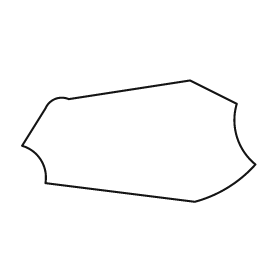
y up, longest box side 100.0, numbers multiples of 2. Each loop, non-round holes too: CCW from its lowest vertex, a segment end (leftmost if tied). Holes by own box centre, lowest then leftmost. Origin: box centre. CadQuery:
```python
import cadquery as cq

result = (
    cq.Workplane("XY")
    .moveTo(24.0, -26.0)
    .threePointArc((38.0, -20.0), (50.0, -10.0))
    .threePointArc((42.0, 2.0), (42.0, 16.0))
    .lineTo(22.0, 26.0)
    .lineTo(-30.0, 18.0)
    .threePointArc((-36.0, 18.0), (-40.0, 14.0))
    .lineTo(-50.0, -2.0)
    .threePointArc((-42.0, -8.0), (-40.0, -18.0))
    .close()
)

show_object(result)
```